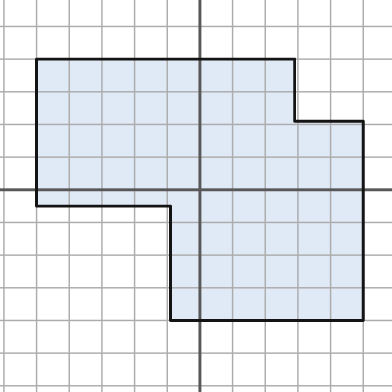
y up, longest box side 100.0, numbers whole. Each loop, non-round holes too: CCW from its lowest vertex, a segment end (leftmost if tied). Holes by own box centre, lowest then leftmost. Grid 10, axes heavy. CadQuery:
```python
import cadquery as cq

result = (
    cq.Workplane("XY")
    .moveTo(-9.0, -40.0)
    .lineTo(50.0, -40.0)
    .lineTo(50.0, 21.0)
    .lineTo(29.0, 21.0)
    .lineTo(29.0, 40.0)
    .lineTo(-50.0, 40.0)
    .lineTo(-50.0, -5.0)
    .lineTo(-9.0, -5.0)
    .close()
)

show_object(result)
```